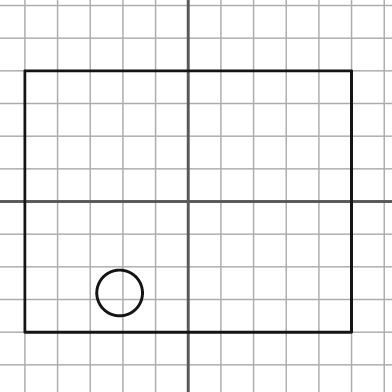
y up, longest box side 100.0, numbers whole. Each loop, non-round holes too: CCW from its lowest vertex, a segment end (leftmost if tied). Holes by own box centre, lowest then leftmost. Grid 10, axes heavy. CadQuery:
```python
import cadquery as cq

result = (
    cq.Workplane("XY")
    .moveTo(-50.0, -40.0)
    .lineTo(50.0, -40.0)
    .lineTo(50.0, 40.0)
    .lineTo(-50.0, 40.0)
    .close()
    .moveTo(-21.0, -28.0)
    .circle(7.0)
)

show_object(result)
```